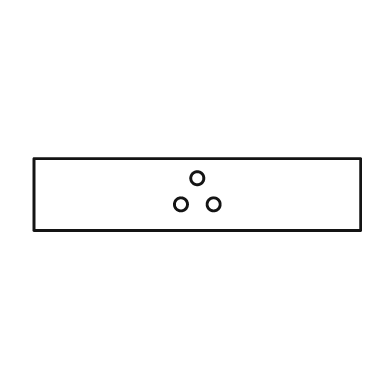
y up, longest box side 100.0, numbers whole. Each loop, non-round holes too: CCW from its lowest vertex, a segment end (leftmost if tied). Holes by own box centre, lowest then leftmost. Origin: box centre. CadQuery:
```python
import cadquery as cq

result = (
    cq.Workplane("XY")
    .moveTo(-50.0, -11.0)
    .lineTo(50.0, -11.0)
    .lineTo(50.0, 11.0)
    .lineTo(-50.0, 11.0)
    .close()
    .moveTo(-5.0, -3.0)
    .circle(2.0)
    .moveTo(5.0, -3.0)
    .circle(2.0)
    .moveTo(0.0, 5.0)
    .circle(2.0)
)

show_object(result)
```